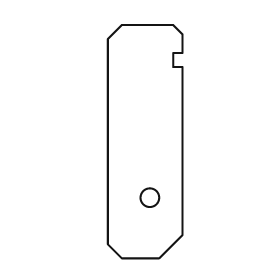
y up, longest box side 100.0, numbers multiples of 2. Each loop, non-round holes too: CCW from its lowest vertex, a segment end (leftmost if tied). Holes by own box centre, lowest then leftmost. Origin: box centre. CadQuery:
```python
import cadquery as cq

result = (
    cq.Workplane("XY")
    .moveTo(-10.0, -50.0)
    .lineTo(6.0, -50.0)
    .lineTo(16.0, -40.0)
    .lineTo(16.0, 32.0)
    .lineTo(12.0, 32.0)
    .lineTo(12.0, 38.0)
    .lineTo(16.0, 38.0)
    .lineTo(16.0, 46.0)
    .lineTo(12.0, 50.0)
    .lineTo(-10.0, 50.0)
    .lineTo(-16.0, 44.0)
    .lineTo(-16.0, -44.0)
    .close()
    .moveTo(2.0, -24.0)
    .circle(4.0)
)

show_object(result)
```